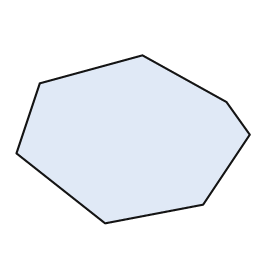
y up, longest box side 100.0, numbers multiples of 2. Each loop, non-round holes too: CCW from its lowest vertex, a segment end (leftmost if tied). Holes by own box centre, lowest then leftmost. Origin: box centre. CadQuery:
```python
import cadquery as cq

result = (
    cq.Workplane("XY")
    .moveTo(-12.0, -36.0)
    .lineTo(30.0, -28.0)
    .lineTo(50.0, 2.0)
    .lineTo(40.0, 16.0)
    .lineTo(4.0, 36.0)
    .lineTo(-40.0, 24.0)
    .lineTo(-50.0, -6.0)
    .close()
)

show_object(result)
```